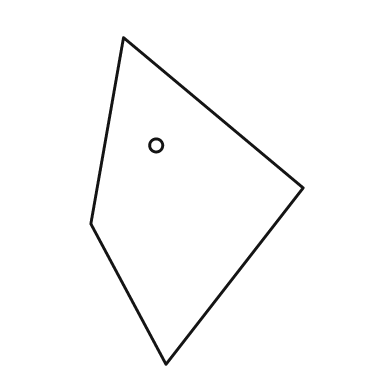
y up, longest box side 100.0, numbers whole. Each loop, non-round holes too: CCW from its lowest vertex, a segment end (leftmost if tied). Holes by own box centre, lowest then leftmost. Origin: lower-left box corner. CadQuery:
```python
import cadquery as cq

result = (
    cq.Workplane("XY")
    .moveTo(23.0, 0.0)
    .lineTo(65.0, 54.0)
    .lineTo(10.0, 100.0)
    .lineTo(0.0, 43.0)
    .close()
    .moveTo(20.0, 67.0)
    .circle(2.0)
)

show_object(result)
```